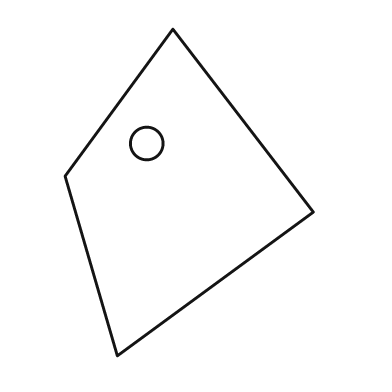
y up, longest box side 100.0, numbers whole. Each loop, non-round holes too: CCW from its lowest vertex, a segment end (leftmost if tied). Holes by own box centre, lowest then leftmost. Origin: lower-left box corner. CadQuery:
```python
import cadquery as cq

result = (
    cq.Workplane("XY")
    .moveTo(16.0, 0.0)
    .lineTo(76.0, 44.0)
    .lineTo(33.0, 100.0)
    .lineTo(0.0, 55.0)
    .close()
    .moveTo(25.0, 65.0)
    .circle(5.0)
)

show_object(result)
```